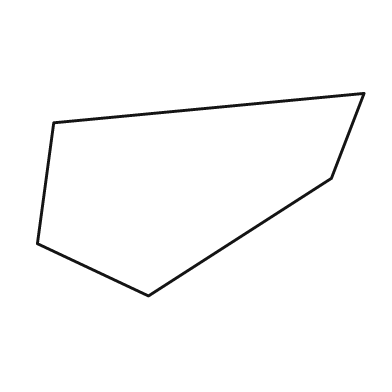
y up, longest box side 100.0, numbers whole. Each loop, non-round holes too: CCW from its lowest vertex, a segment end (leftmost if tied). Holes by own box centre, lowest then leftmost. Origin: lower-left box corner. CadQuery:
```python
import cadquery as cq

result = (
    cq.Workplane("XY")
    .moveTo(34.0, 0.0)
    .lineTo(90.0, 36.0)
    .lineTo(100.0, 62.0)
    .lineTo(5.0, 53.0)
    .lineTo(0.0, 16.0)
    .close()
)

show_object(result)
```